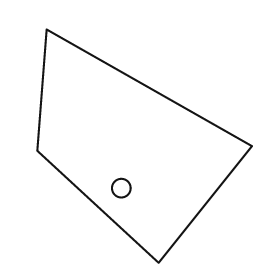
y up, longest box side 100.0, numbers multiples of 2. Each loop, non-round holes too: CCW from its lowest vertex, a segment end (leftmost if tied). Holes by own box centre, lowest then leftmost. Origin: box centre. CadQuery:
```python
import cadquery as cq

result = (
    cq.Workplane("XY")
    .moveTo(6.0, -50.0)
    .lineTo(46.0, 0.0)
    .lineTo(-42.0, 50.0)
    .lineTo(-46.0, -2.0)
    .close()
    .moveTo(-10.0, -18.0)
    .circle(4.0)
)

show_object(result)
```